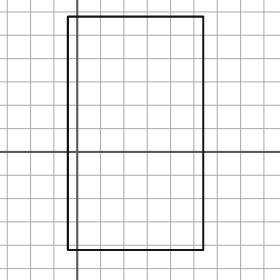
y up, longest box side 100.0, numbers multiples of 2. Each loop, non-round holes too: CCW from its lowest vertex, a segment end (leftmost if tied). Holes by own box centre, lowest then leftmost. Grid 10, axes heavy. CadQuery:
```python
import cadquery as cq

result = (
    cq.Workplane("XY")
    .moveTo(-4.0, -42.0)
    .lineTo(54.0, -42.0)
    .lineTo(54.0, 58.0)
    .lineTo(-4.0, 58.0)
    .close()
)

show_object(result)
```